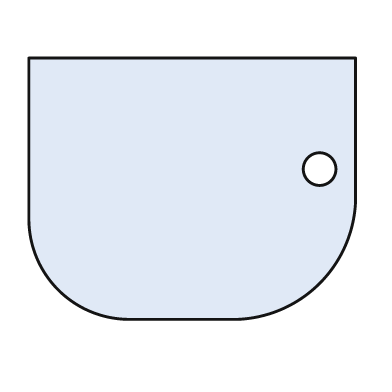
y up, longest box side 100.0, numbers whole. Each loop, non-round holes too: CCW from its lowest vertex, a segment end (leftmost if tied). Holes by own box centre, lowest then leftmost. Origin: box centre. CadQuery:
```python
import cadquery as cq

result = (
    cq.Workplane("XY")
    .moveTo(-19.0, -40.0)
    .lineTo(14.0, -40.0)
    .threePointArc((39.0, -29.0), (50.0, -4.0))
    .lineTo(50.0, 40.0)
    .lineTo(-50.0, 40.0)
    .lineTo(-50.0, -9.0)
    .threePointArc((-41.0, -31.0), (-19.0, -40.0))
    .close()
    .moveTo(39.0, 6.0)
    .circle(5.0)
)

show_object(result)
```